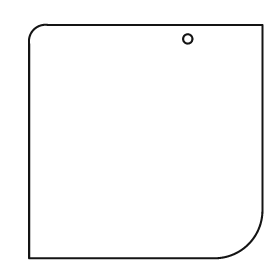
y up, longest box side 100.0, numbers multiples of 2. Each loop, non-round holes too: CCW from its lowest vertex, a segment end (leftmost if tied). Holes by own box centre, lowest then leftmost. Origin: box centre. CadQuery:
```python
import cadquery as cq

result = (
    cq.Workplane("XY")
    .moveTo(-50.0, -50.0)
    .lineTo(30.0, -50.0)
    .threePointArc((44.0, -44.0), (50.0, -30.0))
    .lineTo(50.0, 50.0)
    .lineTo(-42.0, 50.0)
    .threePointArc((-48.0, 48.0), (-50.0, 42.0))
    .close()
    .moveTo(18.0, 44.0)
    .circle(2.0)
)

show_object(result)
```